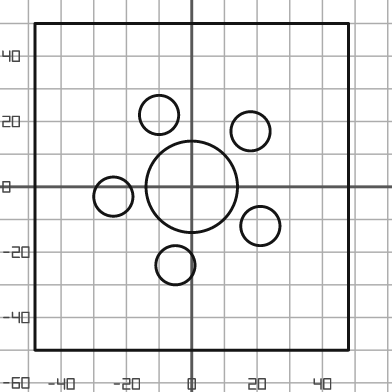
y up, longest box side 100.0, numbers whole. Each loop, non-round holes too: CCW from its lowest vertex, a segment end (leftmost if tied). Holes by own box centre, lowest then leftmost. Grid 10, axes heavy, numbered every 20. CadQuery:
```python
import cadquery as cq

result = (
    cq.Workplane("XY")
    .moveTo(-48.0, -50.0)
    .lineTo(48.0, -50.0)
    .lineTo(48.0, 50.0)
    .lineTo(-48.0, 50.0)
    .close()
    .moveTo(-5.0, -24.0)
    .circle(6.0)
    .moveTo(21.0, -12.0)
    .circle(6.0)
    .moveTo(-24.0, -3.0)
    .circle(6.0)
    .moveTo(0.0, 0.0)
    .circle(14.0)
    .moveTo(18.0, 17.0)
    .circle(6.0)
    .moveTo(-10.0, 22.0)
    .circle(6.0)
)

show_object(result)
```